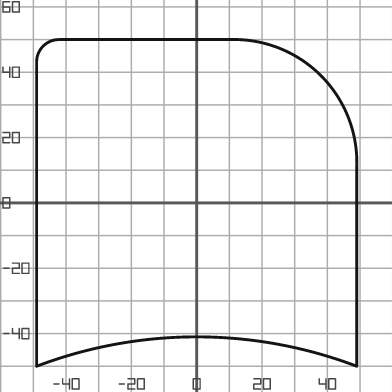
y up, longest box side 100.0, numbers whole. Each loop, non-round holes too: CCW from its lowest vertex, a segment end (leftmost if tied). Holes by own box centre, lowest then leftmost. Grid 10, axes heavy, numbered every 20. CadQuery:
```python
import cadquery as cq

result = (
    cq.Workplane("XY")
    .moveTo(-49.0, -50.0)
    .threePointArc((0.0, -41.0), (49.0, -50.0))
    .lineTo(49.0, 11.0)
    .threePointArc((38.0, 39.0), (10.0, 50.0))
    .lineTo(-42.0, 50.0)
    .threePointArc((-47.0, 48.0), (-49.0, 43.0))
    .close()
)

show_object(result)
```